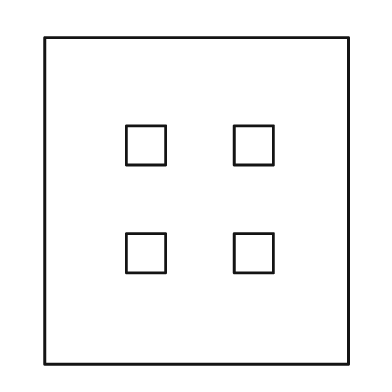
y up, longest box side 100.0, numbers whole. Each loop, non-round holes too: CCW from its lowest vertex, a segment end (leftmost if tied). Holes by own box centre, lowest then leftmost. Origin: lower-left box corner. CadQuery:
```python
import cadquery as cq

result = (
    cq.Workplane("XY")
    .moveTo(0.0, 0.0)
    .lineTo(93.0, 0.0)
    .lineTo(93.0, 100.0)
    .lineTo(0.0, 100.0)
    .close()
    .moveTo(25.0, 28.0)
    .lineTo(37.0, 28.0)
    .lineTo(37.0, 40.0)
    .lineTo(25.0, 40.0)
    .close()
    .moveTo(58.0, 28.0)
    .lineTo(70.0, 28.0)
    .lineTo(70.0, 40.0)
    .lineTo(58.0, 40.0)
    .close()
    .moveTo(25.0, 61.0)
    .lineTo(37.0, 61.0)
    .lineTo(37.0, 73.0)
    .lineTo(25.0, 73.0)
    .close()
    .moveTo(58.0, 61.0)
    .lineTo(70.0, 61.0)
    .lineTo(70.0, 73.0)
    .lineTo(58.0, 73.0)
    .close()
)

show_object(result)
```